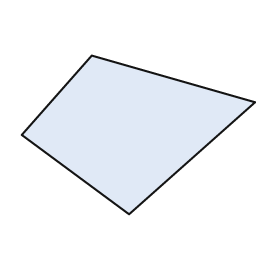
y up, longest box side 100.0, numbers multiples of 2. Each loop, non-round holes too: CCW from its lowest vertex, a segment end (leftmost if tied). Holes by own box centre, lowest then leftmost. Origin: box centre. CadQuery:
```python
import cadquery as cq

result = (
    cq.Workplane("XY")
    .moveTo(-4.0, -34.0)
    .lineTo(50.0, 14.0)
    .lineTo(-20.0, 34.0)
    .lineTo(-50.0, 0.0)
    .close()
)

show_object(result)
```